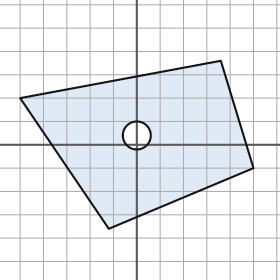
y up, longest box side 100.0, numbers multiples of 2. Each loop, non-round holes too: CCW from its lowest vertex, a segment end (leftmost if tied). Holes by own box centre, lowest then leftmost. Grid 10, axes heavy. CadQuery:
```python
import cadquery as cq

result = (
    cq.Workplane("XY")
    .moveTo(-12.0, -36.0)
    .lineTo(50.0, -10.0)
    .lineTo(36.0, 36.0)
    .lineTo(-50.0, 20.0)
    .close()
    .moveTo(0.0, 4.0)
    .circle(6.0)
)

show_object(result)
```